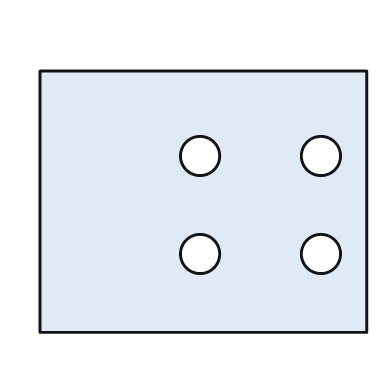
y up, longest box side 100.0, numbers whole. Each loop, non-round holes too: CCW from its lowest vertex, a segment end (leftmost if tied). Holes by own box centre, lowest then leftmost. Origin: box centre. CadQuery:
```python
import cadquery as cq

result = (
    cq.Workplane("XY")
    .moveTo(-50.0, -40.0)
    .lineTo(50.0, -40.0)
    .lineTo(50.0, 40.0)
    .lineTo(-50.0, 40.0)
    .close()
    .moveTo(-1.0, -16.0)
    .circle(6.0)
    .moveTo(36.0, -16.0)
    .circle(6.0)
    .moveTo(-1.0, 14.0)
    .circle(6.0)
    .moveTo(36.0, 14.0)
    .circle(6.0)
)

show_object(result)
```